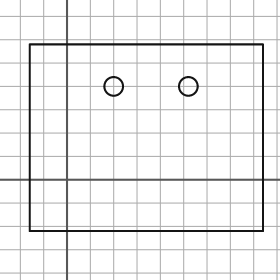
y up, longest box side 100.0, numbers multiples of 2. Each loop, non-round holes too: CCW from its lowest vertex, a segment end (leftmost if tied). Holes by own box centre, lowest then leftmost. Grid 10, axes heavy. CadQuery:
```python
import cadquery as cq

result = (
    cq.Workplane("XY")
    .moveTo(-16.0, -22.0)
    .lineTo(84.0, -22.0)
    .lineTo(84.0, 58.0)
    .lineTo(-16.0, 58.0)
    .close()
    .moveTo(20.0, 40.0)
    .circle(4.0)
    .moveTo(52.0, 40.0)
    .circle(4.0)
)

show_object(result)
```